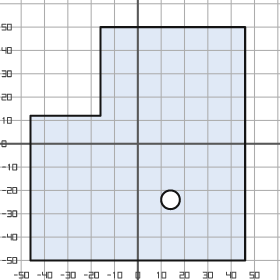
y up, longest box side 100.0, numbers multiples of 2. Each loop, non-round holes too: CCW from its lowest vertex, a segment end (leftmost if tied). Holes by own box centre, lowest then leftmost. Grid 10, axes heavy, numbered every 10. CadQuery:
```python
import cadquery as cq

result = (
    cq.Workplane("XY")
    .moveTo(-46.0, -50.0)
    .lineTo(46.0, -50.0)
    .lineTo(46.0, 50.0)
    .lineTo(-16.0, 50.0)
    .lineTo(-16.0, 12.0)
    .lineTo(-46.0, 12.0)
    .close()
    .moveTo(14.0, -24.0)
    .circle(4.0)
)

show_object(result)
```